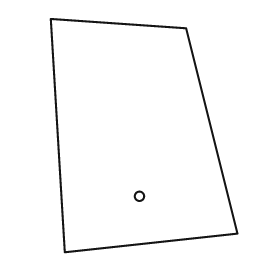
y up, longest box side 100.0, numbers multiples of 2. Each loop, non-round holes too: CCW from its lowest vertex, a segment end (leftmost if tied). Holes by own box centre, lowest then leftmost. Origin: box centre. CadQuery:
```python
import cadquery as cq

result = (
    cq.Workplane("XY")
    .moveTo(-34.0, -50.0)
    .lineTo(40.0, -42.0)
    .lineTo(18.0, 46.0)
    .lineTo(-40.0, 50.0)
    .close()
    .moveTo(-2.0, -26.0)
    .circle(2.0)
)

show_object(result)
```